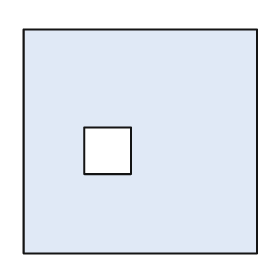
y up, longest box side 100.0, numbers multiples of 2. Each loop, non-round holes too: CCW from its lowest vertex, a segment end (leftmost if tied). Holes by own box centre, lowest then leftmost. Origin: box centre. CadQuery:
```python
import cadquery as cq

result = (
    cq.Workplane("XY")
    .moveTo(-50.0, -48.0)
    .lineTo(50.0, -48.0)
    .lineTo(50.0, 48.0)
    .lineTo(-50.0, 48.0)
    .close()
    .moveTo(-24.0, -14.0)
    .lineTo(-4.0, -14.0)
    .lineTo(-4.0, 6.0)
    .lineTo(-24.0, 6.0)
    .close()
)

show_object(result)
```